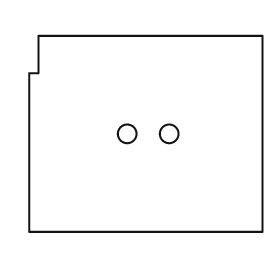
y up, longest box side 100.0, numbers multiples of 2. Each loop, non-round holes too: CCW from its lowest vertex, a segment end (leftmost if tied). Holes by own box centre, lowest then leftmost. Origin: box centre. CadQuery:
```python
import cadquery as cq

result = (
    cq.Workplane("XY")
    .moveTo(-50.0, -42.0)
    .lineTo(50.0, -42.0)
    .lineTo(50.0, 42.0)
    .lineTo(-46.0, 42.0)
    .lineTo(-46.0, 26.0)
    .lineTo(-50.0, 26.0)
    .close()
    .moveTo(-8.0, 0.0)
    .circle(4.0)
    .moveTo(10.0, 0.0)
    .circle(4.0)
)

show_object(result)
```